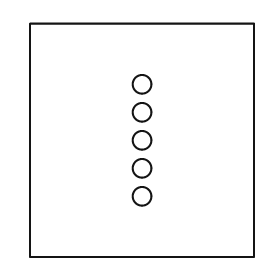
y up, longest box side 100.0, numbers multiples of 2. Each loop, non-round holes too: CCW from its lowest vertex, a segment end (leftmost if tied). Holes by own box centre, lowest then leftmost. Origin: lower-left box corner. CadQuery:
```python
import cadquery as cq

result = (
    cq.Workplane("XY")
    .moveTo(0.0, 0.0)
    .lineTo(96.0, 0.0)
    .lineTo(96.0, 100.0)
    .lineTo(0.0, 100.0)
    .close()
    .moveTo(48.0, 26.0)
    .circle(4.0)
    .moveTo(48.0, 38.0)
    .circle(4.0)
    .moveTo(48.0, 50.0)
    .circle(4.0)
    .moveTo(48.0, 62.0)
    .circle(4.0)
    .moveTo(48.0, 74.0)
    .circle(4.0)
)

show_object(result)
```